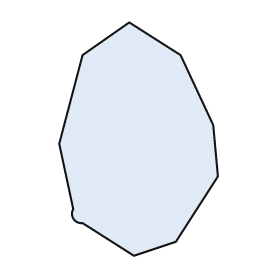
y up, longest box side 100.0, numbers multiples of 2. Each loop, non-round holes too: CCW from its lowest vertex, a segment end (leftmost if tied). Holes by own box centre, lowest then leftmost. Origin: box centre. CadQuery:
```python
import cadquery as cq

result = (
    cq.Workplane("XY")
    .moveTo(-2.0, -50.0)
    .lineTo(16.0, -44.0)
    .lineTo(34.0, -16.0)
    .lineTo(32.0, 6.0)
    .lineTo(18.0, 36.0)
    .lineTo(-4.0, 50.0)
    .lineTo(-24.0, 36.0)
    .lineTo(-34.0, -2.0)
    .lineTo(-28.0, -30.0)
    .threePointArc((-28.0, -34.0), (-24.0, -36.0))
    .close()
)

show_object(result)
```